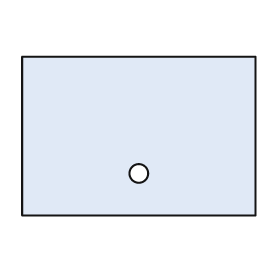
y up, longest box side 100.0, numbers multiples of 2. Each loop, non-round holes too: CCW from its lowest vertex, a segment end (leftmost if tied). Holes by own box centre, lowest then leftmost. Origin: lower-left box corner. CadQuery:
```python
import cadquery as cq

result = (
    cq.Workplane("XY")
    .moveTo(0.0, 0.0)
    .lineTo(100.0, 0.0)
    .lineTo(100.0, 68.0)
    .lineTo(0.0, 68.0)
    .close()
    .moveTo(50.0, 18.0)
    .circle(4.0)
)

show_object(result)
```